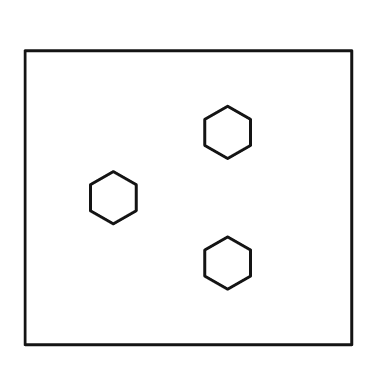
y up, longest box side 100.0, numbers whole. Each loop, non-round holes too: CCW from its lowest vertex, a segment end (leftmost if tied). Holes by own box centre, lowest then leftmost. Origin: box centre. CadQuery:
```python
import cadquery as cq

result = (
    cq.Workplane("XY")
    .moveTo(-50.0, -45.0)
    .lineTo(50.0, -45.0)
    .lineTo(50.0, 45.0)
    .lineTo(-50.0, 45.0)
    .close()
    .moveTo(12.0, -28.0)
    .lineTo(19.0, -24.0)
    .lineTo(19.0, -16.0)
    .lineTo(12.0, -12.0)
    .lineTo(5.0, -16.0)
    .lineTo(5.0, -24.0)
    .close()
    .moveTo(-23.0, -8.0)
    .lineTo(-16.0, -4.0)
    .lineTo(-16.0, 4.0)
    .lineTo(-23.0, 8.0)
    .lineTo(-30.0, 4.0)
    .lineTo(-30.0, -4.0)
    .close()
    .moveTo(12.0, 12.0)
    .lineTo(19.0, 16.0)
    .lineTo(19.0, 24.0)
    .lineTo(12.0, 28.0)
    .lineTo(5.0, 24.0)
    .lineTo(5.0, 16.0)
    .close()
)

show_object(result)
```